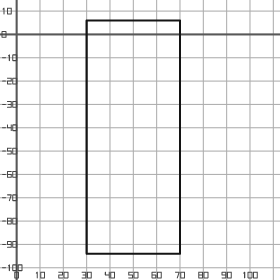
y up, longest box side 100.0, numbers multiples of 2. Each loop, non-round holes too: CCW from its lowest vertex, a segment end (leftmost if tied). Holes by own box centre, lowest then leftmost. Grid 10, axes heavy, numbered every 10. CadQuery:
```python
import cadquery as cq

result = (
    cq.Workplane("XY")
    .moveTo(30.0, -94.0)
    .lineTo(70.0, -94.0)
    .lineTo(70.0, 6.0)
    .lineTo(30.0, 6.0)
    .close()
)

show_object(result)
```